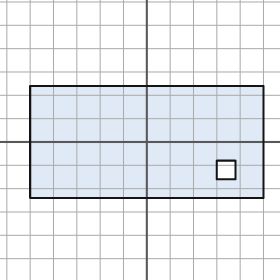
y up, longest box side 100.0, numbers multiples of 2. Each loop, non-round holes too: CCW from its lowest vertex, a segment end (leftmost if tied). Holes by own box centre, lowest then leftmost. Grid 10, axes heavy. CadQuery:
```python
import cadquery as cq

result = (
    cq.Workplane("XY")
    .moveTo(-50.0, -24.0)
    .lineTo(50.0, -24.0)
    .lineTo(50.0, 24.0)
    .lineTo(-50.0, 24.0)
    .close()
    .moveTo(30.0, -16.0)
    .lineTo(38.0, -16.0)
    .lineTo(38.0, -8.0)
    .lineTo(30.0, -8.0)
    .close()
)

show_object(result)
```